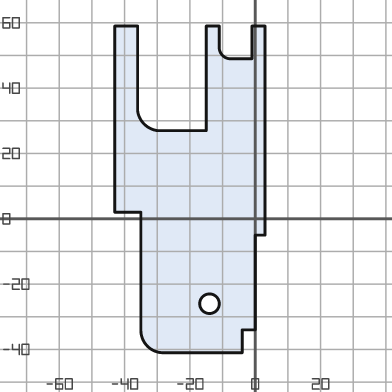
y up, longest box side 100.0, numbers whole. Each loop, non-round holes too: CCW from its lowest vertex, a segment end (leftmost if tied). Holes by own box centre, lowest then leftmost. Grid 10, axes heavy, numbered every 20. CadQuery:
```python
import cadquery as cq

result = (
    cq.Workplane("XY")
    .moveTo(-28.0, -41.0)
    .lineTo(-4.0, -41.0)
    .lineTo(-4.0, -34.0)
    .lineTo(0.0, -34.0)
    .lineTo(0.0, -5.0)
    .lineTo(3.0, -5.0)
    .lineTo(3.0, 59.0)
    .lineTo(-1.0, 59.0)
    .lineTo(-1.0, 49.0)
    .lineTo(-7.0, 49.0)
    .threePointArc((-10.0, 50.0), (-11.0, 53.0))
    .lineTo(-11.0, 59.0)
    .lineTo(-15.0, 59.0)
    .lineTo(-15.0, 27.0)
    .lineTo(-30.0, 27.0)
    .threePointArc((-34.0, 29.0), (-36.0, 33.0))
    .lineTo(-36.0, 59.0)
    .lineTo(-43.0, 59.0)
    .lineTo(-43.0, 2.0)
    .lineTo(-35.0, 2.0)
    .lineTo(-35.0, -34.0)
    .threePointArc((-33.0, -39.0), (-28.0, -41.0))
    .close()
    .moveTo(-14.0, -26.0)
    .circle(3.0)
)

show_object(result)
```